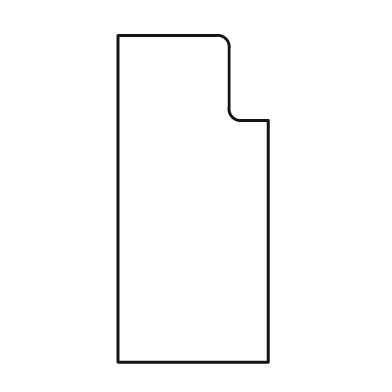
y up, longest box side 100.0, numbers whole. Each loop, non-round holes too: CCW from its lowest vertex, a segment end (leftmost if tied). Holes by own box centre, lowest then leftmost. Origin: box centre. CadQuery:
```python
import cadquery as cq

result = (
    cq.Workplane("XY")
    .moveTo(-23.0, -50.0)
    .lineTo(23.0, -50.0)
    .lineTo(23.0, 24.0)
    .lineTo(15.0, 24.0)
    .threePointArc((12.0, 25.0), (11.0, 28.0))
    .lineTo(11.0, 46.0)
    .threePointArc((10.0, 49.0), (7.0, 50.0))
    .lineTo(-23.0, 50.0)
    .close()
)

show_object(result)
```